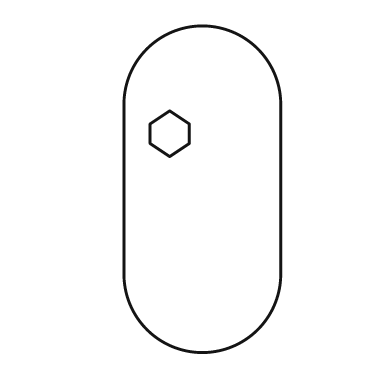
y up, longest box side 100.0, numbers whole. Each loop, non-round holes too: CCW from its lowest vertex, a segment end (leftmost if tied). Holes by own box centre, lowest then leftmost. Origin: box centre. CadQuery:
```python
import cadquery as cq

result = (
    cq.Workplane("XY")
    .moveTo(-24.0, -26.0)
    .threePointArc((0.0, -50.0), (24.0, -26.0))
    .lineTo(24.0, 26.0)
    .threePointArc((0.0, 50.0), (-24.0, 26.0))
    .close()
    .moveTo(-10.0, 10.0)
    .lineTo(-4.0, 14.0)
    .lineTo(-4.0, 20.0)
    .lineTo(-10.0, 24.0)
    .lineTo(-16.0, 20.0)
    .lineTo(-16.0, 14.0)
    .close()
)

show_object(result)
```